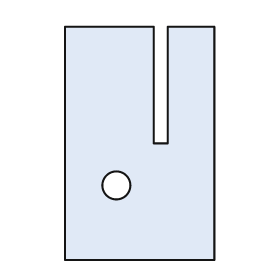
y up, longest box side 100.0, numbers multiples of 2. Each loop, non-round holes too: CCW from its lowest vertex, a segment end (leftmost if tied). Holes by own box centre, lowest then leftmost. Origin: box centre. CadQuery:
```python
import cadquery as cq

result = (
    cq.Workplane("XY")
    .moveTo(-32.0, -50.0)
    .lineTo(32.0, -50.0)
    .lineTo(32.0, 50.0)
    .lineTo(12.0, 50.0)
    .lineTo(12.0, 0.0)
    .lineTo(6.0, 0.0)
    .lineTo(6.0, 50.0)
    .lineTo(-32.0, 50.0)
    .close()
    .moveTo(-10.0, -18.0)
    .circle(6.0)
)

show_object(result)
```